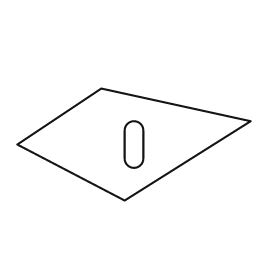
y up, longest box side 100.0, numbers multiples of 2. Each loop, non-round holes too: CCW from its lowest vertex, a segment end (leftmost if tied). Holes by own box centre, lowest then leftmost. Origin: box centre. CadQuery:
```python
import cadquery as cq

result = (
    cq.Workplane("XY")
    .moveTo(-4.0, -24.0)
    .lineTo(50.0, 10.0)
    .lineTo(-14.0, 24.0)
    .lineTo(-50.0, 0.0)
    .close()
    .moveTo(-4.0, -6.0)
    .threePointArc((0.0, -10.0), (4.0, -6.0))
    .lineTo(4.0, 6.0)
    .threePointArc((0.0, 10.0), (-4.0, 6.0))
    .close()
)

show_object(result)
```